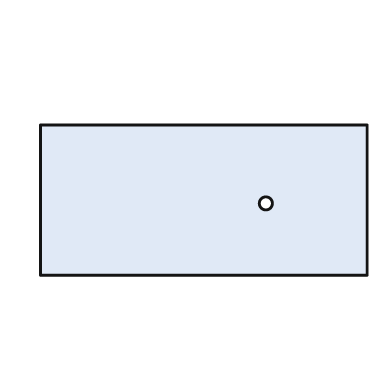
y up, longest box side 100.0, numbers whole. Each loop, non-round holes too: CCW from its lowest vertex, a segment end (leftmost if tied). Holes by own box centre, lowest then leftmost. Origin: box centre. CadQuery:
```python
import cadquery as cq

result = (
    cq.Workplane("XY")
    .moveTo(-50.0, -23.0)
    .lineTo(50.0, -23.0)
    .lineTo(50.0, 23.0)
    .lineTo(-50.0, 23.0)
    .close()
    .moveTo(19.0, -1.0)
    .circle(2.0)
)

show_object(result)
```